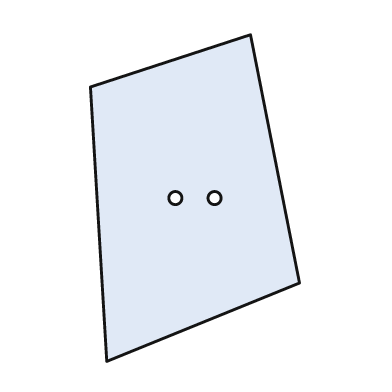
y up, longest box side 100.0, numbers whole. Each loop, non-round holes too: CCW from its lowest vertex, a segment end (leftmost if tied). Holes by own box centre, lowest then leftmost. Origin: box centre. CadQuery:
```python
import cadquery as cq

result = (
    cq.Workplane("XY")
    .moveTo(-27.0, -50.0)
    .lineTo(32.0, -26.0)
    .lineTo(17.0, 50.0)
    .lineTo(-32.0, 34.0)
    .close()
    .moveTo(-6.0, 0.0)
    .circle(2.0)
    .moveTo(6.0, 0.0)
    .circle(2.0)
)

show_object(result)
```